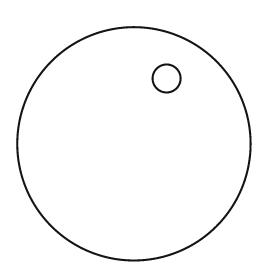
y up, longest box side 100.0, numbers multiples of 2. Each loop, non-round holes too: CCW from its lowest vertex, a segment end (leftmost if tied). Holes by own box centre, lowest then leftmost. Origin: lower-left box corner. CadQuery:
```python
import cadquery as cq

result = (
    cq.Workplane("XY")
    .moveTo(50.0, 50.0)
    .circle(50.0)
    .moveTo(64.0, 78.0)
    .circle(6.0)
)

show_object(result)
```